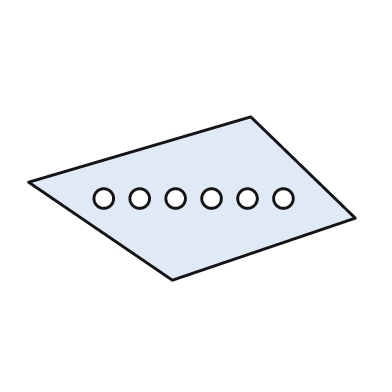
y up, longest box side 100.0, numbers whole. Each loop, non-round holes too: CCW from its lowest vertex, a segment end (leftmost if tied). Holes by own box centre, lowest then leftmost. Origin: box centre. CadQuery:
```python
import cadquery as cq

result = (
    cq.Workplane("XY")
    .moveTo(-6.0, -25.0)
    .lineTo(50.0, -6.0)
    .lineTo(18.0, 25.0)
    .lineTo(-50.0, 5.0)
    .close()
    .moveTo(-27.0, 0.0)
    .circle(3.0)
    .moveTo(-16.0, 0.0)
    .circle(3.0)
    .moveTo(-5.0, 0.0)
    .circle(3.0)
    .moveTo(6.0, 0.0)
    .circle(3.0)
    .moveTo(17.0, 0.0)
    .circle(3.0)
    .moveTo(28.0, 0.0)
    .circle(3.0)
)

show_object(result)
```